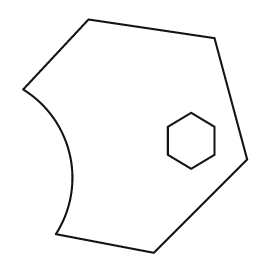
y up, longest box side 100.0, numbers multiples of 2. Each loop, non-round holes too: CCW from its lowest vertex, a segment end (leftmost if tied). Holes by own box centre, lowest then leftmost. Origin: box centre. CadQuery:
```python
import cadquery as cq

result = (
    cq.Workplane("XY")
    .moveTo(8.0, -50.0)
    .lineTo(48.0, -10.0)
    .lineTo(34.0, 42.0)
    .lineTo(-20.0, 50.0)
    .lineTo(-48.0, 20.0)
    .threePointArc((-28.0, -8.0), (-34.0, -42.0))
    .close()
    .moveTo(24.0, -14.0)
    .lineTo(34.0, -8.0)
    .lineTo(34.0, 4.0)
    .lineTo(24.0, 10.0)
    .lineTo(14.0, 4.0)
    .lineTo(14.0, -8.0)
    .close()
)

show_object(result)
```